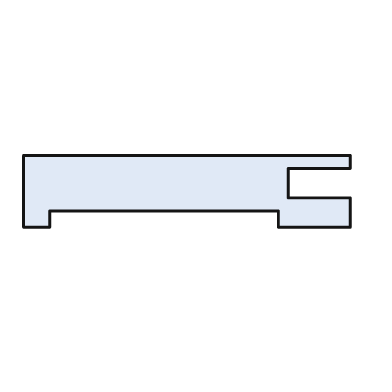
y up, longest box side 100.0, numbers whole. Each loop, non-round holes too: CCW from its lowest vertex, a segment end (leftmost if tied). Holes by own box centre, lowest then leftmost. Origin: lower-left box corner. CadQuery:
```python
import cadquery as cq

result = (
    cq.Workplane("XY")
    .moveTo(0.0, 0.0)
    .lineTo(8.0, 0.0)
    .lineTo(8.0, 5.0)
    .lineTo(78.0, 5.0)
    .lineTo(78.0, 0.0)
    .lineTo(100.0, 0.0)
    .lineTo(100.0, 9.0)
    .lineTo(81.0, 9.0)
    .lineTo(81.0, 18.0)
    .lineTo(100.0, 18.0)
    .lineTo(100.0, 22.0)
    .lineTo(0.0, 22.0)
    .close()
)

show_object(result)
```